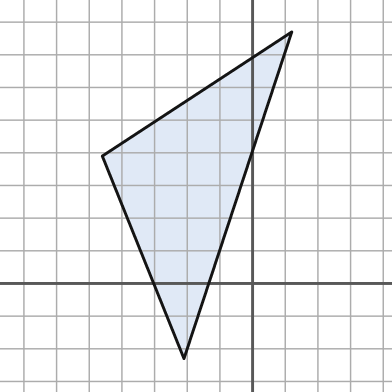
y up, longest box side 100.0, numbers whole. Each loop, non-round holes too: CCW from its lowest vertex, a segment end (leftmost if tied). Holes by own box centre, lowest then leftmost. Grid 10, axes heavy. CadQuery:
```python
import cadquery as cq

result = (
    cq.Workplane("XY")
    .moveTo(-21.0, -23.0)
    .lineTo(12.0, 77.0)
    .lineTo(-46.0, 39.0)
    .close()
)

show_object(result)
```